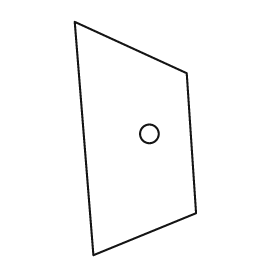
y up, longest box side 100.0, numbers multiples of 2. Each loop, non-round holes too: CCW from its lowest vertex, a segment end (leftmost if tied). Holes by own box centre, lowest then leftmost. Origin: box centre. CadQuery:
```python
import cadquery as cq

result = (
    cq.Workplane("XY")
    .moveTo(-18.0, -50.0)
    .lineTo(26.0, -32.0)
    .lineTo(22.0, 28.0)
    .lineTo(-26.0, 50.0)
    .close()
    .moveTo(6.0, 2.0)
    .circle(4.0)
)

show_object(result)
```